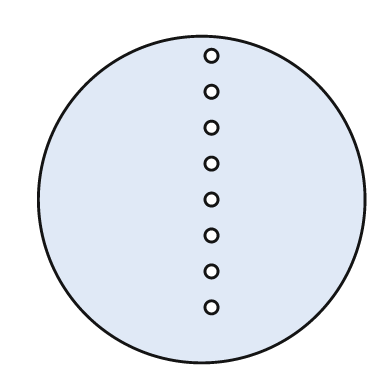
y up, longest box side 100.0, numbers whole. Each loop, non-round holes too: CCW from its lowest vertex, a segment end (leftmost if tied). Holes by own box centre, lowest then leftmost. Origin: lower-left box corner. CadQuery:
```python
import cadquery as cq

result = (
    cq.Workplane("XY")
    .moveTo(50.0, 50.0)
    .circle(50.0)
    .moveTo(53.0, 17.0)
    .circle(2.0)
    .moveTo(53.0, 28.0)
    .circle(2.0)
    .moveTo(53.0, 39.0)
    .circle(2.0)
    .moveTo(53.0, 50.0)
    .circle(2.0)
    .moveTo(53.0, 61.0)
    .circle(2.0)
    .moveTo(53.0, 72.0)
    .circle(2.0)
    .moveTo(53.0, 83.0)
    .circle(2.0)
    .moveTo(53.0, 94.0)
    .circle(2.0)
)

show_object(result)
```